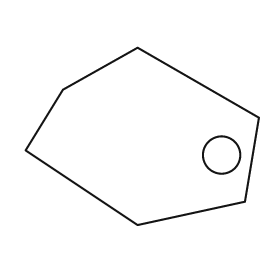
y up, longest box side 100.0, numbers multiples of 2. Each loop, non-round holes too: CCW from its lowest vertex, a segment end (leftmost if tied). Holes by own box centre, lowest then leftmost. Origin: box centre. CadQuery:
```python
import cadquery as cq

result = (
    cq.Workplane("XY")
    .moveTo(-2.0, -38.0)
    .lineTo(44.0, -28.0)
    .lineTo(50.0, 8.0)
    .lineTo(-2.0, 38.0)
    .lineTo(-34.0, 20.0)
    .lineTo(-50.0, -6.0)
    .close()
    .moveTo(34.0, -8.0)
    .circle(8.0)
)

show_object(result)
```